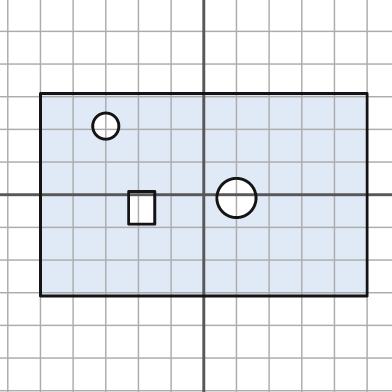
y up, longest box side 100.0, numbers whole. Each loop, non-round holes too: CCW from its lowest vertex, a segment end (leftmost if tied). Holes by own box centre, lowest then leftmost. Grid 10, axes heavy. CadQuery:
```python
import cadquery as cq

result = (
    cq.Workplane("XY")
    .moveTo(-50.0, -31.0)
    .lineTo(50.0, -31.0)
    .lineTo(50.0, 31.0)
    .lineTo(-50.0, 31.0)
    .close()
    .moveTo(-23.0, -9.0)
    .lineTo(-15.0, -9.0)
    .lineTo(-15.0, 1.0)
    .lineTo(-23.0, 1.0)
    .close()
    .moveTo(10.0, -1.0)
    .circle(6.0)
    .moveTo(-30.0, 21.0)
    .circle(4.0)
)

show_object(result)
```